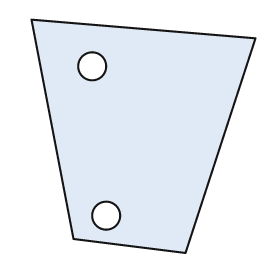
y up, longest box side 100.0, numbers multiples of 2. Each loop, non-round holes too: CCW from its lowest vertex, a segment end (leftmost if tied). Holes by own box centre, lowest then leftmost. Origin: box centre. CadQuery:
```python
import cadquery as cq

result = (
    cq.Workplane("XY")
    .moveTo(18.0, -50.0)
    .lineTo(48.0, 42.0)
    .lineTo(-48.0, 50.0)
    .lineTo(-30.0, -44.0)
    .close()
    .moveTo(-16.0, -34.0)
    .circle(6.0)
    .moveTo(-22.0, 30.0)
    .circle(6.0)
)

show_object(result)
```